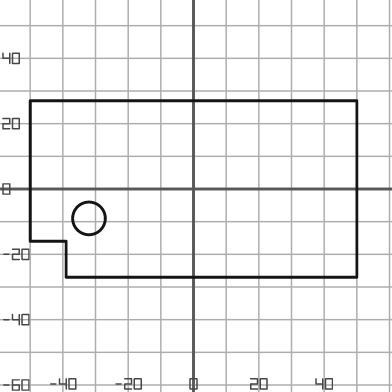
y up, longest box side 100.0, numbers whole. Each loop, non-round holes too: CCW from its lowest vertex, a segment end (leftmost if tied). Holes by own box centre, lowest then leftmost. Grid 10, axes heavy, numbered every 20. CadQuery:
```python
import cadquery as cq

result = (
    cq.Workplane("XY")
    .moveTo(-39.0, -27.0)
    .lineTo(50.0, -27.0)
    .lineTo(50.0, 27.0)
    .lineTo(-50.0, 27.0)
    .lineTo(-50.0, -16.0)
    .lineTo(-39.0, -16.0)
    .close()
    .moveTo(-32.0, -9.0)
    .circle(5.0)
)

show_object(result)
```